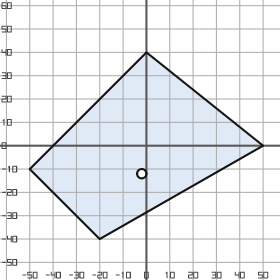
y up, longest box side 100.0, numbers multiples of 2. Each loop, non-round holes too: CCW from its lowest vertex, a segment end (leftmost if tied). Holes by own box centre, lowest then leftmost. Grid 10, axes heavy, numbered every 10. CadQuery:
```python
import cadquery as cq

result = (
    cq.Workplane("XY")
    .moveTo(-20.0, -40.0)
    .lineTo(50.0, 0.0)
    .lineTo(0.0, 40.0)
    .lineTo(-50.0, -10.0)
    .close()
    .moveTo(-2.0, -12.0)
    .circle(2.0)
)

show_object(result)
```